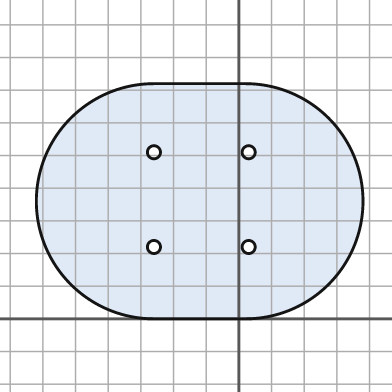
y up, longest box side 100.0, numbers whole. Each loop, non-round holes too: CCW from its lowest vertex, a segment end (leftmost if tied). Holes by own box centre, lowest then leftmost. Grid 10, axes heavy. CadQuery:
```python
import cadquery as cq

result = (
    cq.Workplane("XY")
    .moveTo(-26.0, 0.0)
    .lineTo(2.0, 0.0)
    .threePointArc((38.0, 36.0), (2.0, 72.0))
    .lineTo(-26.0, 72.0)
    .threePointArc((-62.0, 36.0), (-26.0, 0.0))
    .close()
    .moveTo(-26.0, 22.0)
    .circle(2.0)
    .moveTo(3.0, 22.0)
    .circle(2.0)
    .moveTo(-26.0, 51.0)
    .circle(2.0)
    .moveTo(3.0, 51.0)
    .circle(2.0)
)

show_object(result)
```